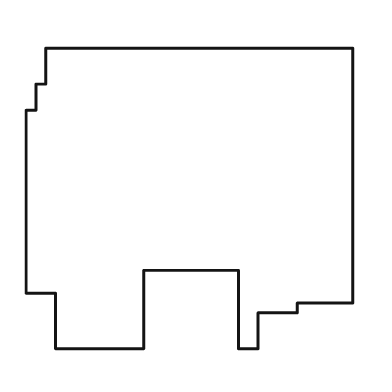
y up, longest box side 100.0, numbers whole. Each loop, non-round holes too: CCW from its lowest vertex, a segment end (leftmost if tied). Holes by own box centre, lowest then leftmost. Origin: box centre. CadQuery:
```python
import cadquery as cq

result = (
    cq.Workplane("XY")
    .moveTo(-41.0, -46.0)
    .lineTo(-14.0, -46.0)
    .lineTo(-14.0, -22.0)
    .lineTo(15.0, -22.0)
    .lineTo(15.0, -46.0)
    .lineTo(21.0, -46.0)
    .lineTo(21.0, -35.0)
    .lineTo(33.0, -35.0)
    .lineTo(33.0, -32.0)
    .lineTo(50.0, -32.0)
    .lineTo(50.0, 46.0)
    .lineTo(-44.0, 46.0)
    .lineTo(-44.0, 35.0)
    .lineTo(-47.0, 35.0)
    .lineTo(-47.0, 27.0)
    .lineTo(-50.0, 27.0)
    .lineTo(-50.0, -29.0)
    .lineTo(-41.0, -29.0)
    .close()
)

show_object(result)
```